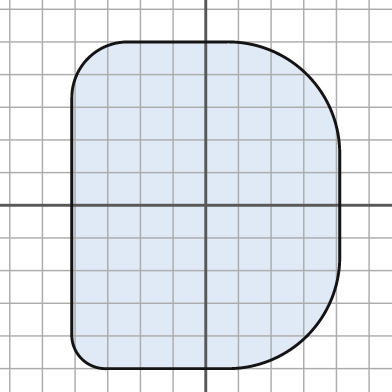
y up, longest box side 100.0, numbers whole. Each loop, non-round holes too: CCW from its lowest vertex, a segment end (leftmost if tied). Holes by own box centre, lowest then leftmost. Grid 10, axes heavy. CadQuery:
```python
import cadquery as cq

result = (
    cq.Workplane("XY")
    .moveTo(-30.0, -50.0)
    .lineTo(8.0, -50.0)
    .threePointArc((31.0, -40.0), (41.0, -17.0))
    .lineTo(41.0, 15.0)
    .threePointArc((31.0, 40.0), (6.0, 50.0))
    .lineTo(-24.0, 50.0)
    .threePointArc((-36.0, 45.0), (-41.0, 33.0))
    .lineTo(-41.0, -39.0)
    .threePointArc((-38.0, -47.0), (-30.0, -50.0))
    .close()
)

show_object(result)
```